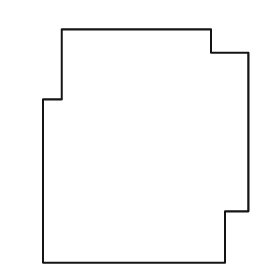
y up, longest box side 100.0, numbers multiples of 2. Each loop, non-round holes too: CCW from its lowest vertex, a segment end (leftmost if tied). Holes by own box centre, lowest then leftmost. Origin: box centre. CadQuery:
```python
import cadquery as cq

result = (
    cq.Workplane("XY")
    .moveTo(-44.0, -50.0)
    .lineTo(34.0, -50.0)
    .lineTo(34.0, -28.0)
    .lineTo(44.0, -28.0)
    .lineTo(44.0, 40.0)
    .lineTo(28.0, 40.0)
    .lineTo(28.0, 50.0)
    .lineTo(-36.0, 50.0)
    .lineTo(-36.0, 20.0)
    .lineTo(-44.0, 20.0)
    .close()
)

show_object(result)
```